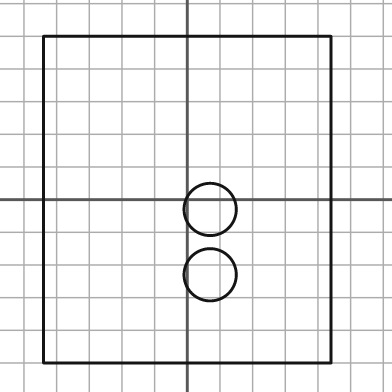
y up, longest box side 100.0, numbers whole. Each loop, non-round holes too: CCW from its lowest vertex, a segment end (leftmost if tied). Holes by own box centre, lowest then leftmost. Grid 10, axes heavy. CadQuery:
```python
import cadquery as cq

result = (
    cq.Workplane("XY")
    .moveTo(-44.0, -50.0)
    .lineTo(44.0, -50.0)
    .lineTo(44.0, 50.0)
    .lineTo(-44.0, 50.0)
    .close()
    .moveTo(7.0, -23.0)
    .circle(8.0)
    .moveTo(7.0, -3.0)
    .circle(8.0)
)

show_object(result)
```